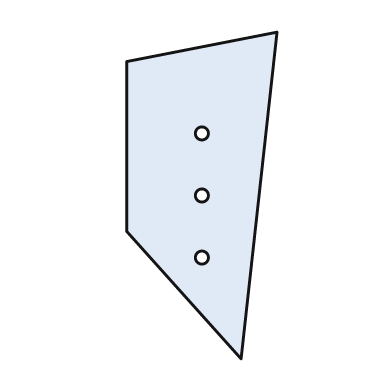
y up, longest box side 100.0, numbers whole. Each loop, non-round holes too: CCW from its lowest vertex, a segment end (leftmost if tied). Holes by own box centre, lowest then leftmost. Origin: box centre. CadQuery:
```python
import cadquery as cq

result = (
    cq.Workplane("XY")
    .moveTo(12.0, -50.0)
    .lineTo(23.0, 50.0)
    .lineTo(-23.0, 41.0)
    .lineTo(-23.0, -11.0)
    .close()
    .moveTo(0.0, -19.0)
    .circle(2.0)
    .moveTo(0.0, 0.0)
    .circle(2.0)
    .moveTo(0.0, 19.0)
    .circle(2.0)
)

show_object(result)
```